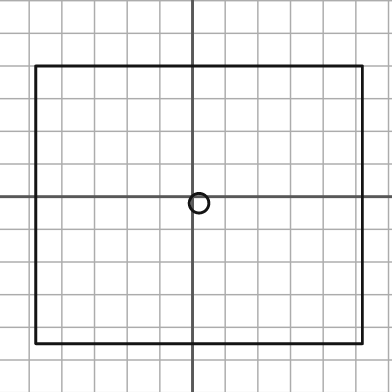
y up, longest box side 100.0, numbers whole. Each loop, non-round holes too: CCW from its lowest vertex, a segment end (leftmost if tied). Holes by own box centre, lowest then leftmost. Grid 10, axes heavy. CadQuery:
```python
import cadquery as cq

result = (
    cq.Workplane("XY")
    .moveTo(-48.0, -45.0)
    .lineTo(52.0, -45.0)
    .lineTo(52.0, 40.0)
    .lineTo(-48.0, 40.0)
    .close()
    .moveTo(2.0, -2.0)
    .circle(3.0)
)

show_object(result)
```